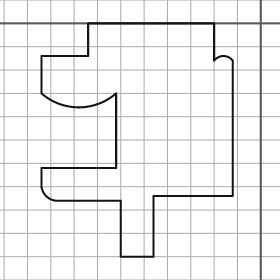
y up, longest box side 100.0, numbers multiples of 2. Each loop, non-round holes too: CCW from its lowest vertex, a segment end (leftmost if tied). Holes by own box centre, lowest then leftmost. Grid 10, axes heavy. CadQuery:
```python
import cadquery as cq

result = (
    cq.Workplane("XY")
    .moveTo(-60.0, -100.0)
    .lineTo(-46.0, -100.0)
    .lineTo(-46.0, -74.0)
    .lineTo(-12.0, -74.0)
    .lineTo(-12.0, -16.0)
    .threePointArc((-16.0, -14.0), (-20.0, -16.0))
    .lineTo(-20.0, 0.0)
    .lineTo(-74.0, 0.0)
    .lineTo(-74.0, -14.0)
    .lineTo(-94.0, -14.0)
    .lineTo(-94.0, -30.0)
    .threePointArc((-78.0, -36.0), (-62.0, -30.0))
    .lineTo(-62.0, -62.0)
    .lineTo(-94.0, -62.0)
    .lineTo(-94.0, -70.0)
    .threePointArc((-92.0, -74.0), (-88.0, -76.0))
    .lineTo(-60.0, -76.0)
    .close()
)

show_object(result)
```